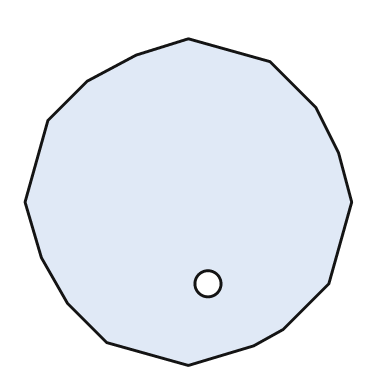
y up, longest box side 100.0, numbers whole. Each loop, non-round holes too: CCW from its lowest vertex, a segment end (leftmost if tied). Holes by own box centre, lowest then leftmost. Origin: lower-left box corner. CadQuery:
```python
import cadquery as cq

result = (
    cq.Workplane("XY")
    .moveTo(50.0, 0.0)
    .lineTo(70.0, 6.0)
    .lineTo(79.0, 11.0)
    .lineTo(93.0, 25.0)
    .lineTo(100.0, 50.0)
    .lineTo(96.0, 65.0)
    .lineTo(89.0, 79.0)
    .lineTo(75.0, 93.0)
    .lineTo(50.0, 100.0)
    .lineTo(34.0, 95.0)
    .lineTo(19.0, 87.0)
    .lineTo(7.0, 75.0)
    .lineTo(0.0, 50.0)
    .lineTo(5.0, 33.0)
    .lineTo(13.0, 19.0)
    .lineTo(25.0, 7.0)
    .close()
    .moveTo(56.0, 25.0)
    .circle(4.0)
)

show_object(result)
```